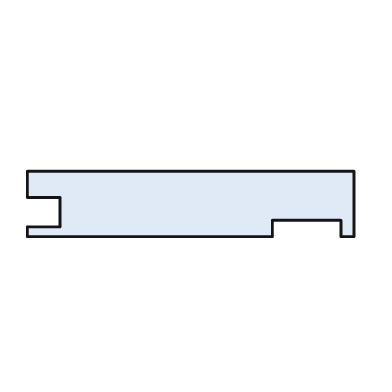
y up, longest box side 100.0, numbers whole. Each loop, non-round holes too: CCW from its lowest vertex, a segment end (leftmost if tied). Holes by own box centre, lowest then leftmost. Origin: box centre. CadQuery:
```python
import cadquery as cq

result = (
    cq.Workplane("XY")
    .moveTo(-50.0, -10.0)
    .lineTo(25.0, -10.0)
    .lineTo(25.0, -5.0)
    .lineTo(46.0, -5.0)
    .lineTo(46.0, -10.0)
    .lineTo(50.0, -10.0)
    .lineTo(50.0, 10.0)
    .lineTo(-50.0, 10.0)
    .lineTo(-50.0, 2.0)
    .lineTo(-40.0, 2.0)
    .lineTo(-40.0, -7.0)
    .lineTo(-50.0, -7.0)
    .close()
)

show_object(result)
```